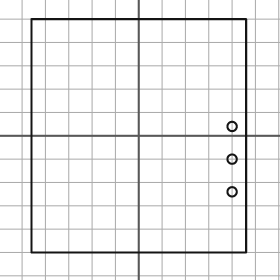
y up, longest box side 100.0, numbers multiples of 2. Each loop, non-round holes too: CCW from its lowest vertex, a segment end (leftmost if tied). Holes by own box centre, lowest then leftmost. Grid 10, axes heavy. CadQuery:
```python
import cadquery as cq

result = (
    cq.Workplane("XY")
    .moveTo(-46.0, -50.0)
    .lineTo(46.0, -50.0)
    .lineTo(46.0, 50.0)
    .lineTo(-46.0, 50.0)
    .close()
    .moveTo(40.0, -24.0)
    .circle(2.0)
    .moveTo(40.0, -10.0)
    .circle(2.0)
    .moveTo(40.0, 4.0)
    .circle(2.0)
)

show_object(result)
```